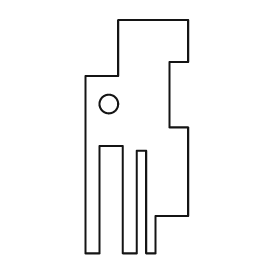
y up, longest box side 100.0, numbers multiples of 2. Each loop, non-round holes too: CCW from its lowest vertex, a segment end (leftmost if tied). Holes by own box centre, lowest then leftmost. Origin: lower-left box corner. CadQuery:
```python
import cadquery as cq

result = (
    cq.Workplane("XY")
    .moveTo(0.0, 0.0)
    .lineTo(6.0, 0.0)
    .lineTo(6.0, 46.0)
    .lineTo(16.0, 46.0)
    .lineTo(16.0, 0.0)
    .lineTo(22.0, 0.0)
    .lineTo(22.0, 44.0)
    .lineTo(26.0, 44.0)
    .lineTo(26.0, 0.0)
    .lineTo(30.0, 0.0)
    .lineTo(30.0, 16.0)
    .lineTo(44.0, 16.0)
    .lineTo(44.0, 54.0)
    .lineTo(36.0, 54.0)
    .lineTo(36.0, 82.0)
    .lineTo(44.0, 82.0)
    .lineTo(44.0, 100.0)
    .lineTo(14.0, 100.0)
    .lineTo(14.0, 76.0)
    .lineTo(0.0, 76.0)
    .close()
    .moveTo(10.0, 64.0)
    .circle(4.0)
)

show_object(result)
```